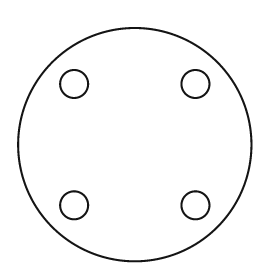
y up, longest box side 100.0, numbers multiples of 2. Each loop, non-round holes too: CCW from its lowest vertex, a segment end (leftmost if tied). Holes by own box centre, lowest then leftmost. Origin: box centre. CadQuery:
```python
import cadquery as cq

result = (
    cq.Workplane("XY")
    .moveTo(0.0, 0.0)
    .circle(50.0)
    .moveTo(-26.0, -26.0)
    .circle(6.0)
    .moveTo(26.0, -26.0)
    .circle(6.0)
    .moveTo(-26.0, 26.0)
    .circle(6.0)
    .moveTo(26.0, 26.0)
    .circle(6.0)
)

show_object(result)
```